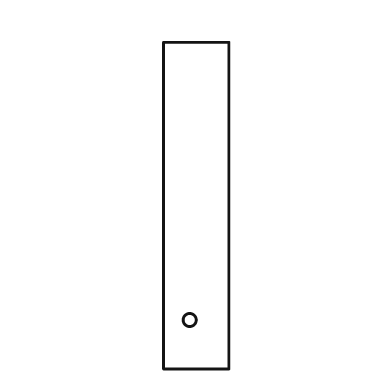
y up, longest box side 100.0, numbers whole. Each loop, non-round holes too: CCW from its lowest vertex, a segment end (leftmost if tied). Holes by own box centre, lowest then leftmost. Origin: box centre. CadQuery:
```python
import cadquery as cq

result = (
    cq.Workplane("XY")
    .moveTo(-10.0, -50.0)
    .lineTo(10.0, -50.0)
    .lineTo(10.0, 50.0)
    .lineTo(-10.0, 50.0)
    .close()
    .moveTo(-2.0, -35.0)
    .circle(2.0)
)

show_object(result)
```